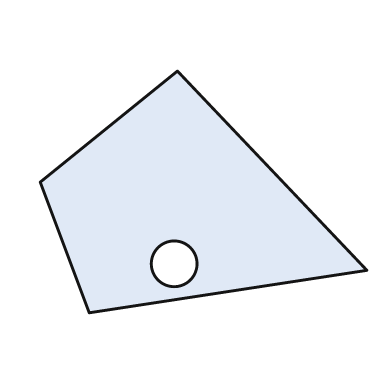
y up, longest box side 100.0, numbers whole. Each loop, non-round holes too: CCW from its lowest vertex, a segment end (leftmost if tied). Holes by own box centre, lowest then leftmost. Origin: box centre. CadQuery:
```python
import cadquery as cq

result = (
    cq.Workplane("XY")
    .moveTo(-35.0, -37.0)
    .lineTo(50.0, -24.0)
    .lineTo(-8.0, 37.0)
    .lineTo(-50.0, 3.0)
    .close()
    .moveTo(-9.0, -22.0)
    .circle(7.0)
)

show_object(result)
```